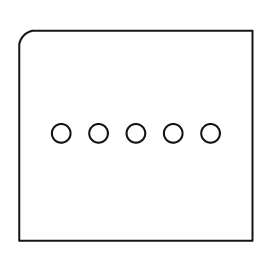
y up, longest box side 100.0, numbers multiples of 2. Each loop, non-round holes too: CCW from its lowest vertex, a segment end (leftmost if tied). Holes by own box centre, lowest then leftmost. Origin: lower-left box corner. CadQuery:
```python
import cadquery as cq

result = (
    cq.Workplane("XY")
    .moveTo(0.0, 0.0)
    .lineTo(100.0, 0.0)
    .lineTo(100.0, 90.0)
    .lineTo(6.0, 90.0)
    .threePointArc((2.0, 88.0), (0.0, 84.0))
    .close()
    .moveTo(18.0, 46.0)
    .circle(4.0)
    .moveTo(34.0, 46.0)
    .circle(4.0)
    .moveTo(50.0, 46.0)
    .circle(4.0)
    .moveTo(66.0, 46.0)
    .circle(4.0)
    .moveTo(82.0, 46.0)
    .circle(4.0)
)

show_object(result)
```